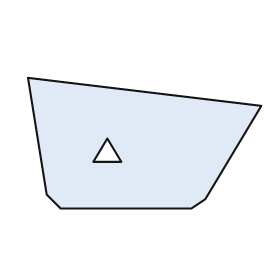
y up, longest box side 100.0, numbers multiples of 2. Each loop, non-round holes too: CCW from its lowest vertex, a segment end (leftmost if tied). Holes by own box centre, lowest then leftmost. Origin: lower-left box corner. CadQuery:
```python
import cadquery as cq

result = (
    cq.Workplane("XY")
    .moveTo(14.0, 0.0)
    .lineTo(70.0, 0.0)
    .lineTo(76.0, 4.0)
    .lineTo(100.0, 44.0)
    .lineTo(0.0, 56.0)
    .lineTo(8.0, 6.0)
    .close()
    .moveTo(28.0, 20.0)
    .lineTo(40.0, 20.0)
    .lineTo(34.0, 30.0)
    .close()
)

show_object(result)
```